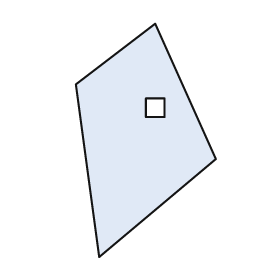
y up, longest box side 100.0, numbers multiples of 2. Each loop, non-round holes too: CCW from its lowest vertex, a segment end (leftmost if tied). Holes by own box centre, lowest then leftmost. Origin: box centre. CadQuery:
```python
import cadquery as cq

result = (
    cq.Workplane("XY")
    .moveTo(-20.0, -50.0)
    .lineTo(30.0, -8.0)
    .lineTo(4.0, 50.0)
    .lineTo(-30.0, 24.0)
    .close()
    .moveTo(0.0, 10.0)
    .lineTo(8.0, 10.0)
    .lineTo(8.0, 18.0)
    .lineTo(0.0, 18.0)
    .close()
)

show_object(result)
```